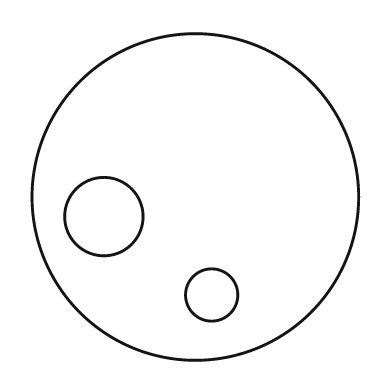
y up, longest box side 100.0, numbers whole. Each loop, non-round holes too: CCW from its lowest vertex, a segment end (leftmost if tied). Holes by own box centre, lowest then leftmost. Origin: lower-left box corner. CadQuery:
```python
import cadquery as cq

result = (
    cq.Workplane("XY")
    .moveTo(50.0, 50.0)
    .circle(50.0)
    .moveTo(55.0, 20.0)
    .circle(8.0)
    .moveTo(22.0, 44.0)
    .circle(12.0)
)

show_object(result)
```